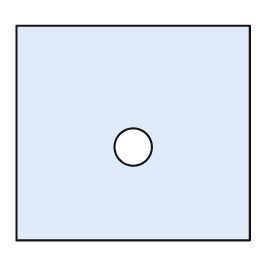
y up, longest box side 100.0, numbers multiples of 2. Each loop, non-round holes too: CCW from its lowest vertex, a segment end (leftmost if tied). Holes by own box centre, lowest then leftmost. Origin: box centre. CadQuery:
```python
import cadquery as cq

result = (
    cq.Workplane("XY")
    .moveTo(-50.0, -46.0)
    .lineTo(50.0, -46.0)
    .lineTo(50.0, 46.0)
    .lineTo(-50.0, 46.0)
    .close()
    .moveTo(0.0, -6.0)
    .circle(8.0)
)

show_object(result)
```